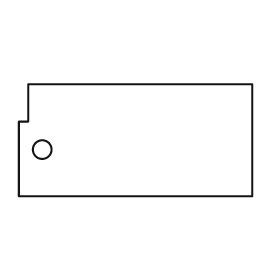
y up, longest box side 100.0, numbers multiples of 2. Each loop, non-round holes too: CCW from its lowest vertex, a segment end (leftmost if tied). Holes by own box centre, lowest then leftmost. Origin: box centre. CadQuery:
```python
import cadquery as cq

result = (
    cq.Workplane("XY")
    .moveTo(-50.0, -24.0)
    .lineTo(50.0, -24.0)
    .lineTo(50.0, 24.0)
    .lineTo(-46.0, 24.0)
    .lineTo(-46.0, 8.0)
    .lineTo(-50.0, 8.0)
    .close()
    .moveTo(-40.0, -4.0)
    .circle(4.0)
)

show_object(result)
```